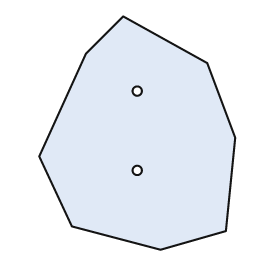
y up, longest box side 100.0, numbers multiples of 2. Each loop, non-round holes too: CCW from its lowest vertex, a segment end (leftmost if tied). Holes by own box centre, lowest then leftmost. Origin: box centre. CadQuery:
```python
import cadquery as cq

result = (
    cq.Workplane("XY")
    .moveTo(10.0, -50.0)
    .lineTo(38.0, -42.0)
    .lineTo(42.0, -2.0)
    .lineTo(30.0, 30.0)
    .lineTo(-6.0, 50.0)
    .lineTo(-22.0, 34.0)
    .lineTo(-42.0, -10.0)
    .lineTo(-28.0, -40.0)
    .close()
    .moveTo(0.0, -16.0)
    .circle(2.0)
    .moveTo(0.0, 18.0)
    .circle(2.0)
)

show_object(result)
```